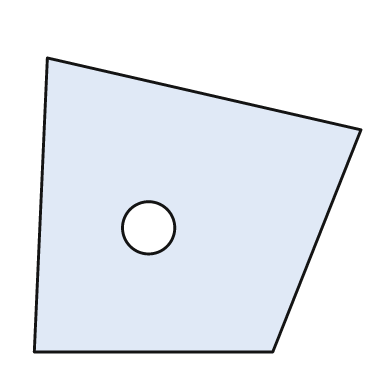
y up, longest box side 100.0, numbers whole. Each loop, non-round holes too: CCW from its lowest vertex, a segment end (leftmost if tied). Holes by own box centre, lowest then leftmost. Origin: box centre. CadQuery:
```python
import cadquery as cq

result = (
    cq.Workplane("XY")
    .moveTo(-50.0, -45.0)
    .lineTo(23.0, -45.0)
    .lineTo(50.0, 23.0)
    .lineTo(-46.0, 45.0)
    .close()
    .moveTo(-15.0, -7.0)
    .circle(8.0)
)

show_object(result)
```